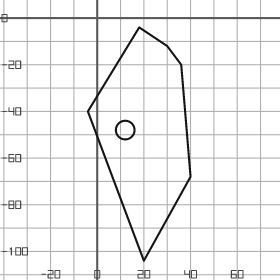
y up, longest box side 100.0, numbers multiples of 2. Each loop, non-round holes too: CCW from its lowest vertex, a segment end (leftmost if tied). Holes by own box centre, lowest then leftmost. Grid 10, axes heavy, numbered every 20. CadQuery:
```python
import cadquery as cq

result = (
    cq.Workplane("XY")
    .moveTo(20.0, -104.0)
    .lineTo(40.0, -68.0)
    .lineTo(36.0, -20.0)
    .lineTo(30.0, -12.0)
    .lineTo(18.0, -4.0)
    .lineTo(-4.0, -40.0)
    .close()
    .moveTo(12.0, -48.0)
    .circle(4.0)
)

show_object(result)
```